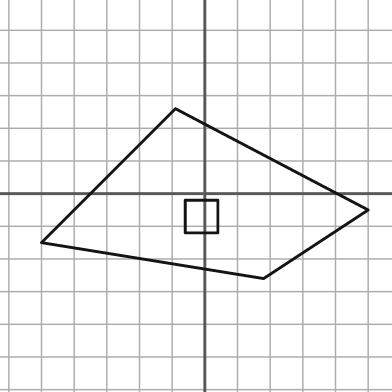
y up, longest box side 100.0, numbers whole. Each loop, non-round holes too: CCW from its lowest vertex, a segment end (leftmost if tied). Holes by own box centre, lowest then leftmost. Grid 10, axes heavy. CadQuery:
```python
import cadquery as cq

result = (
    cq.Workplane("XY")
    .moveTo(18.0, -26.0)
    .lineTo(50.0, -5.0)
    .lineTo(-9.0, 26.0)
    .lineTo(-50.0, -15.0)
    .close()
    .moveTo(-6.0, -12.0)
    .lineTo(4.0, -12.0)
    .lineTo(4.0, -2.0)
    .lineTo(-6.0, -2.0)
    .close()
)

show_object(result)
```